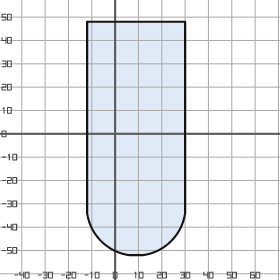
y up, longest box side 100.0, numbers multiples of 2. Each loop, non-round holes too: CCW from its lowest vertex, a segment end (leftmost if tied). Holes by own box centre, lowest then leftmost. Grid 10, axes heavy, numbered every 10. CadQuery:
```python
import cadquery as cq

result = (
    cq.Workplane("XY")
    .moveTo(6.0, -52.0)
    .lineTo(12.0, -52.0)
    .threePointArc((24.0, -46.0), (30.0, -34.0))
    .lineTo(30.0, 48.0)
    .lineTo(-12.0, 48.0)
    .lineTo(-12.0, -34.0)
    .threePointArc((-6.0, -46.0), (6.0, -52.0))
    .close()
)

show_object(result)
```